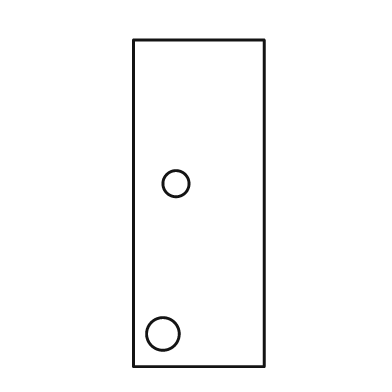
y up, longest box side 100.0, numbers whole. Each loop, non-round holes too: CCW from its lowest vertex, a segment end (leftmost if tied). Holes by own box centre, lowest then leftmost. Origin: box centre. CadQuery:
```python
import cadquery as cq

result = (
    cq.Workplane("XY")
    .moveTo(-20.0, -50.0)
    .lineTo(20.0, -50.0)
    .lineTo(20.0, 50.0)
    .lineTo(-20.0, 50.0)
    .close()
    .moveTo(-11.0, -40.0)
    .circle(5.0)
    .moveTo(-7.0, 6.0)
    .circle(4.0)
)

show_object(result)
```